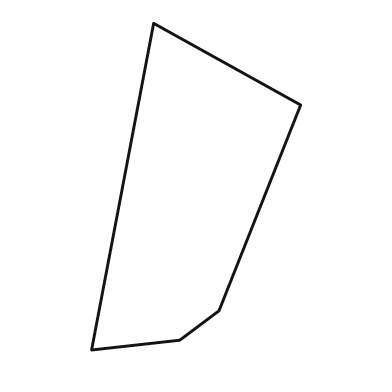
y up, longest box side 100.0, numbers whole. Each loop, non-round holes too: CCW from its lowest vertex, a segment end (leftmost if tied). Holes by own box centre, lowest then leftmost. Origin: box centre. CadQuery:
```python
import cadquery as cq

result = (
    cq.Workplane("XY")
    .moveTo(-32.0, -50.0)
    .lineTo(-5.0, -47.0)
    .lineTo(7.0, -38.0)
    .lineTo(32.0, 25.0)
    .lineTo(-13.0, 50.0)
    .close()
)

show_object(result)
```